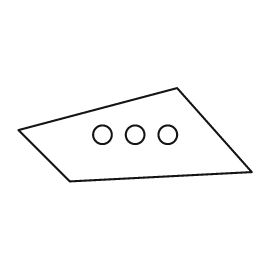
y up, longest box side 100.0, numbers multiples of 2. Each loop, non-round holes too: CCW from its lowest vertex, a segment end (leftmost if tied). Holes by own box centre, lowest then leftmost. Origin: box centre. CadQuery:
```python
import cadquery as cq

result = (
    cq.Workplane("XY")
    .moveTo(-28.0, -20.0)
    .lineTo(50.0, -16.0)
    .lineTo(18.0, 20.0)
    .lineTo(-50.0, 2.0)
    .close()
    .moveTo(-14.0, 0.0)
    .circle(4.0)
    .moveTo(0.0, 0.0)
    .circle(4.0)
    .moveTo(14.0, 0.0)
    .circle(4.0)
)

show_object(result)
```